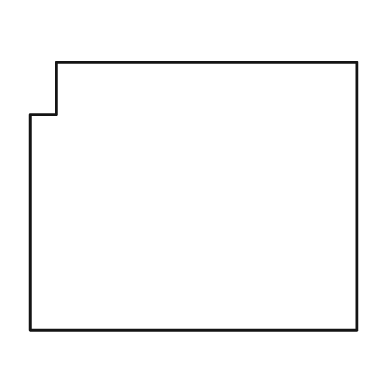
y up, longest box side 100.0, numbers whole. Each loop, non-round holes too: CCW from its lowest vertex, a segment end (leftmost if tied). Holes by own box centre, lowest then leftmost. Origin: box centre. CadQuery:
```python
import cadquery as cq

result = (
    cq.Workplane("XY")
    .moveTo(-50.0, -41.0)
    .lineTo(50.0, -41.0)
    .lineTo(50.0, 41.0)
    .lineTo(-42.0, 41.0)
    .lineTo(-42.0, 25.0)
    .lineTo(-50.0, 25.0)
    .close()
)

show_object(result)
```